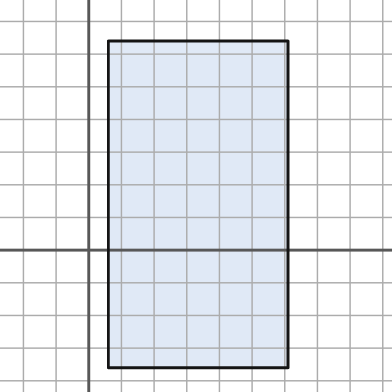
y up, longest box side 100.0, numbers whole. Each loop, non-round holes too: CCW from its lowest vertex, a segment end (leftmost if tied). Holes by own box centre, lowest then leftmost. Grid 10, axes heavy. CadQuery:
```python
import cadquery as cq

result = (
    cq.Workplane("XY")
    .moveTo(6.0, -36.0)
    .lineTo(61.0, -36.0)
    .lineTo(61.0, 64.0)
    .lineTo(6.0, 64.0)
    .close()
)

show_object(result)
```